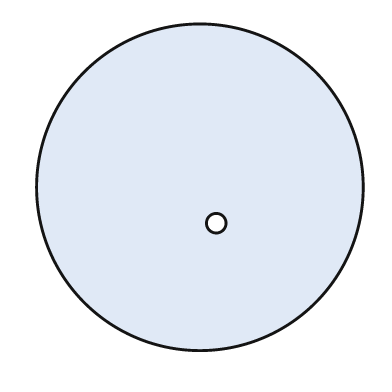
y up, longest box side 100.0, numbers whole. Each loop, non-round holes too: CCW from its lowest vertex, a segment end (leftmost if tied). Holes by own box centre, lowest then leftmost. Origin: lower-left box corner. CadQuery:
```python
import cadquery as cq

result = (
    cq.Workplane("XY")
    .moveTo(50.0, 50.0)
    .circle(50.0)
    .moveTo(55.0, 39.0)
    .circle(3.0)
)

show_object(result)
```